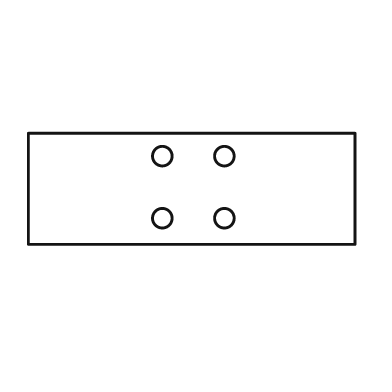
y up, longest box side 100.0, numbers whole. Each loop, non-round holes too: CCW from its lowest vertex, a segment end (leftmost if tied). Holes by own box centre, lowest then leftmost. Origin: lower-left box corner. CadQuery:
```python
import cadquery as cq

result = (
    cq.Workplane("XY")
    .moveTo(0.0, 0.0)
    .lineTo(100.0, 0.0)
    .lineTo(100.0, 34.0)
    .lineTo(0.0, 34.0)
    .close()
    .moveTo(41.0, 8.0)
    .circle(3.0)
    .moveTo(60.0, 8.0)
    .circle(3.0)
    .moveTo(41.0, 27.0)
    .circle(3.0)
    .moveTo(60.0, 27.0)
    .circle(3.0)
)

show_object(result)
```